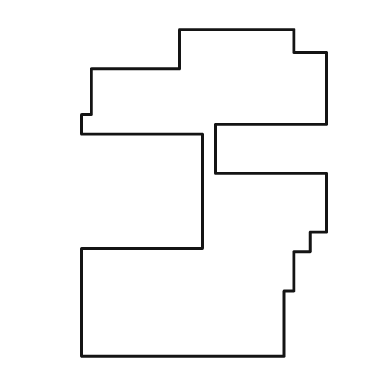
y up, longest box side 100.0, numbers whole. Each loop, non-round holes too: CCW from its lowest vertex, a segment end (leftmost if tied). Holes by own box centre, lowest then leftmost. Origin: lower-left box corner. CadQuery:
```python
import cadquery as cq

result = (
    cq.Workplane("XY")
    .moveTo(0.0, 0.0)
    .lineTo(62.0, 0.0)
    .lineTo(62.0, 20.0)
    .lineTo(65.0, 20.0)
    .lineTo(65.0, 32.0)
    .lineTo(70.0, 32.0)
    .lineTo(70.0, 38.0)
    .lineTo(75.0, 38.0)
    .lineTo(75.0, 56.0)
    .lineTo(41.0, 56.0)
    .lineTo(41.0, 71.0)
    .lineTo(75.0, 71.0)
    .lineTo(75.0, 93.0)
    .lineTo(65.0, 93.0)
    .lineTo(65.0, 100.0)
    .lineTo(30.0, 100.0)
    .lineTo(30.0, 88.0)
    .lineTo(3.0, 88.0)
    .lineTo(3.0, 74.0)
    .lineTo(0.0, 74.0)
    .lineTo(0.0, 68.0)
    .lineTo(37.0, 68.0)
    .lineTo(37.0, 33.0)
    .lineTo(0.0, 33.0)
    .close()
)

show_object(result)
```